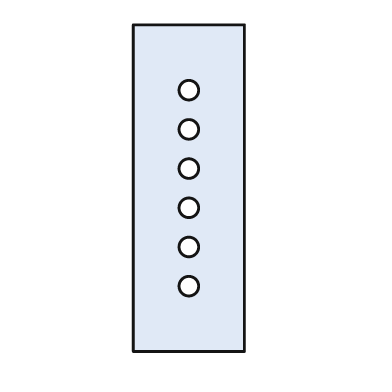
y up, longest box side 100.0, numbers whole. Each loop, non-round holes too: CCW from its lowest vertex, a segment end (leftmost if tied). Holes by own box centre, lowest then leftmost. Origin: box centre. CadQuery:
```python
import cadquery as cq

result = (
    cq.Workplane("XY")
    .moveTo(-17.0, -50.0)
    .lineTo(17.0, -50.0)
    .lineTo(17.0, 50.0)
    .lineTo(-17.0, 50.0)
    .close()
    .moveTo(0.0, -30.0)
    .circle(3.0)
    .moveTo(0.0, -18.0)
    .circle(3.0)
    .moveTo(0.0, -6.0)
    .circle(3.0)
    .moveTo(0.0, 6.0)
    .circle(3.0)
    .moveTo(0.0, 18.0)
    .circle(3.0)
    .moveTo(0.0, 30.0)
    .circle(3.0)
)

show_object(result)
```